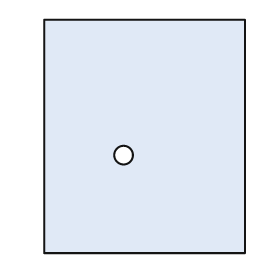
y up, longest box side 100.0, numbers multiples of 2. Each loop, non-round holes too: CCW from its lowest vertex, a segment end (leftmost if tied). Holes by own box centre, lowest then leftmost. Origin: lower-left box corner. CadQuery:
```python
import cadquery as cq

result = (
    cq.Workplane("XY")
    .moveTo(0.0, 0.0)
    .lineTo(86.0, 0.0)
    .lineTo(86.0, 100.0)
    .lineTo(0.0, 100.0)
    .close()
    .moveTo(34.0, 42.0)
    .circle(4.0)
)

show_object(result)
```